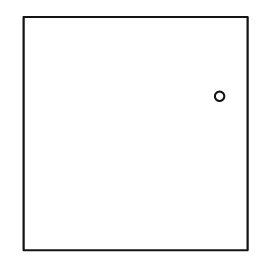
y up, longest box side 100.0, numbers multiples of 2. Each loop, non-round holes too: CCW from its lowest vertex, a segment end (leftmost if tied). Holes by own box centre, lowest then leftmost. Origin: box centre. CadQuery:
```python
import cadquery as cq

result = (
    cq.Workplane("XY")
    .moveTo(-48.0, -50.0)
    .lineTo(48.0, -50.0)
    .lineTo(48.0, 50.0)
    .lineTo(-48.0, 50.0)
    .close()
    .moveTo(36.0, 16.0)
    .circle(2.0)
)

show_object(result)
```